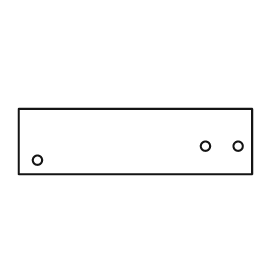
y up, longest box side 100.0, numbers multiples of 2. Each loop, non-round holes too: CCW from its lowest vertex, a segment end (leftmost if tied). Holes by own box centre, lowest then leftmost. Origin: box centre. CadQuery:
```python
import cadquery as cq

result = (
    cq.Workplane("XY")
    .moveTo(-50.0, -14.0)
    .lineTo(50.0, -14.0)
    .lineTo(50.0, 14.0)
    .lineTo(-50.0, 14.0)
    .close()
    .moveTo(-42.0, -8.0)
    .circle(2.0)
    .moveTo(30.0, -2.0)
    .circle(2.0)
    .moveTo(44.0, -2.0)
    .circle(2.0)
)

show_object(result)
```